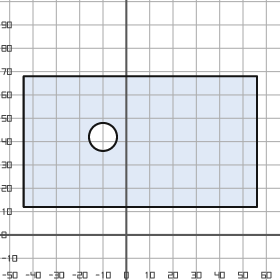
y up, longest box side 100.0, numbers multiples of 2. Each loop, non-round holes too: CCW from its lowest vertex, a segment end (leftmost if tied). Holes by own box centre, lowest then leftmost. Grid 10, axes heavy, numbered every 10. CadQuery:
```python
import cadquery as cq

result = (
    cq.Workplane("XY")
    .moveTo(-44.0, 12.0)
    .lineTo(56.0, 12.0)
    .lineTo(56.0, 68.0)
    .lineTo(-44.0, 68.0)
    .close()
    .moveTo(-10.0, 42.0)
    .circle(6.0)
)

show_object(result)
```